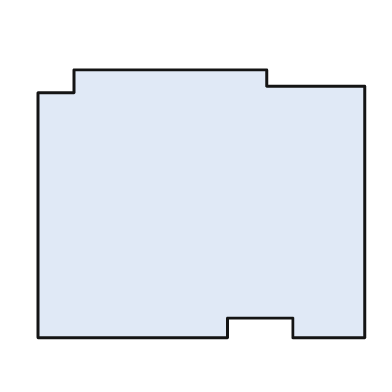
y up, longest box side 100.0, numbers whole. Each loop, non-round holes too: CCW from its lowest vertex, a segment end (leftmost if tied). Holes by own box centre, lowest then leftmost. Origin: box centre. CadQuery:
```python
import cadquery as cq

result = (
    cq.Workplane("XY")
    .moveTo(-50.0, -41.0)
    .lineTo(8.0, -41.0)
    .lineTo(8.0, -35.0)
    .lineTo(28.0, -35.0)
    .lineTo(28.0, -41.0)
    .lineTo(50.0, -41.0)
    .lineTo(50.0, 36.0)
    .lineTo(20.0, 36.0)
    .lineTo(20.0, 41.0)
    .lineTo(-39.0, 41.0)
    .lineTo(-39.0, 34.0)
    .lineTo(-50.0, 34.0)
    .close()
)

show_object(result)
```